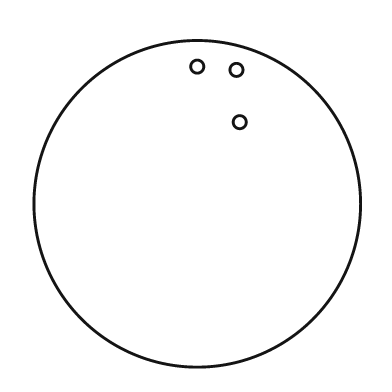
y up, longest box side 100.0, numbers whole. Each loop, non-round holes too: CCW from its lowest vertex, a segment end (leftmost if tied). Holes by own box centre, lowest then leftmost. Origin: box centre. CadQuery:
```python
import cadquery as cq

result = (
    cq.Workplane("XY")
    .moveTo(0.0, 0.0)
    .circle(50.0)
    .moveTo(13.0, 25.0)
    .circle(2.0)
    .moveTo(12.0, 41.0)
    .circle(2.0)
    .moveTo(0.0, 42.0)
    .circle(2.0)
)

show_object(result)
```